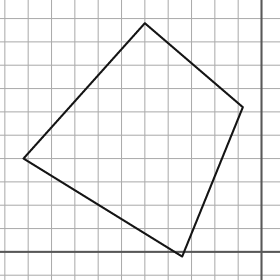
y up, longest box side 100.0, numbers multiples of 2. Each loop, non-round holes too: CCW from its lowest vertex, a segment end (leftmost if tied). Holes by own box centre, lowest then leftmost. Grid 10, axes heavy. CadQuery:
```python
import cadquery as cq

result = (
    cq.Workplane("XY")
    .moveTo(-34.0, -2.0)
    .lineTo(-8.0, 62.0)
    .lineTo(-50.0, 98.0)
    .lineTo(-102.0, 40.0)
    .close()
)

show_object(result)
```